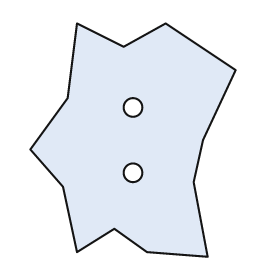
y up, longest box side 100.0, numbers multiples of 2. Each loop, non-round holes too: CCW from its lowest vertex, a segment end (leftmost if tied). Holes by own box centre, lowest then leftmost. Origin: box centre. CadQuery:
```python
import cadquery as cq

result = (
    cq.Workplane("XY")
    .moveTo(32.0, -50.0)
    .lineTo(26.0, -18.0)
    .lineTo(30.0, 0.0)
    .lineTo(44.0, 30.0)
    .lineTo(14.0, 50.0)
    .lineTo(-4.0, 40.0)
    .lineTo(-24.0, 50.0)
    .lineTo(-28.0, 18.0)
    .lineTo(-44.0, -4.0)
    .lineTo(-30.0, -20.0)
    .lineTo(-24.0, -48.0)
    .lineTo(-8.0, -38.0)
    .lineTo(6.0, -48.0)
    .close()
    .moveTo(0.0, -14.0)
    .circle(4.0)
    .moveTo(0.0, 14.0)
    .circle(4.0)
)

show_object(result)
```